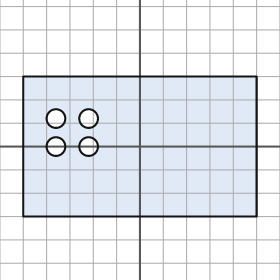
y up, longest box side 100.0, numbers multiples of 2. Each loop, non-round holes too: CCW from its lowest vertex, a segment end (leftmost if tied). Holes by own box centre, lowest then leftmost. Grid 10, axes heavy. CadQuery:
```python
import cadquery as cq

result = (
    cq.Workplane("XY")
    .moveTo(-50.0, -30.0)
    .lineTo(50.0, -30.0)
    .lineTo(50.0, 30.0)
    .lineTo(-50.0, 30.0)
    .close()
    .moveTo(-36.0, 0.0)
    .circle(4.0)
    .moveTo(-22.0, 0.0)
    .circle(4.0)
    .moveTo(-36.0, 12.0)
    .circle(4.0)
    .moveTo(-22.0, 12.0)
    .circle(4.0)
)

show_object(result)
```